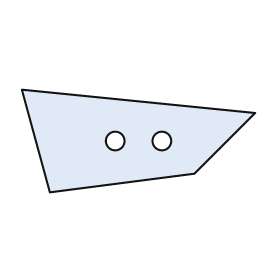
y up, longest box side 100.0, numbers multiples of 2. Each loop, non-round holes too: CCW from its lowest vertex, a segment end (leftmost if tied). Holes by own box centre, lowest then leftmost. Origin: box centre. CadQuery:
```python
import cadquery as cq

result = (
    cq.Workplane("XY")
    .moveTo(-38.0, -22.0)
    .lineTo(24.0, -14.0)
    .lineTo(50.0, 12.0)
    .lineTo(-50.0, 22.0)
    .close()
    .moveTo(-10.0, 0.0)
    .circle(4.0)
    .moveTo(10.0, 0.0)
    .circle(4.0)
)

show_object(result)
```